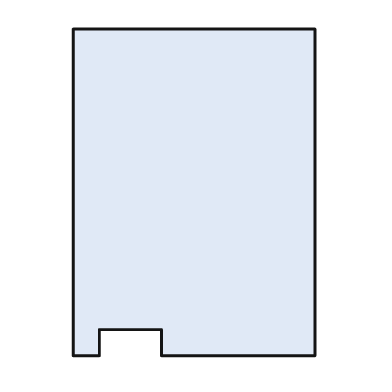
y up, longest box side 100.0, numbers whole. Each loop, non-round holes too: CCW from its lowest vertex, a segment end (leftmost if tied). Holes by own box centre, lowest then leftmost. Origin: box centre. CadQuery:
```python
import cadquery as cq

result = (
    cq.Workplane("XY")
    .moveTo(-37.0, -50.0)
    .lineTo(-29.0, -50.0)
    .lineTo(-29.0, -42.0)
    .lineTo(-10.0, -42.0)
    .lineTo(-10.0, -50.0)
    .lineTo(37.0, -50.0)
    .lineTo(37.0, 50.0)
    .lineTo(-37.0, 50.0)
    .close()
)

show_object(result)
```